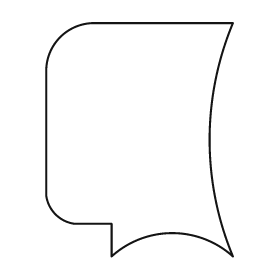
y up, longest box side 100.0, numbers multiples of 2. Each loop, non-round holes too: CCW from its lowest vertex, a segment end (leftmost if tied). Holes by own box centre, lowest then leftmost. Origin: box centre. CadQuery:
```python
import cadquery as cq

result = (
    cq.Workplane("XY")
    .moveTo(-12.0, -50.0)
    .threePointArc((14.0, -40.0), (40.0, -50.0))
    .threePointArc((30.0, 0.0), (40.0, 50.0))
    .lineTo(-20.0, 50.0)
    .threePointArc((-34.0, 44.0), (-40.0, 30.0))
    .lineTo(-40.0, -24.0)
    .threePointArc((-36.0, -32.0), (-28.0, -36.0))
    .lineTo(-12.0, -36.0)
    .close()
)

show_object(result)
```